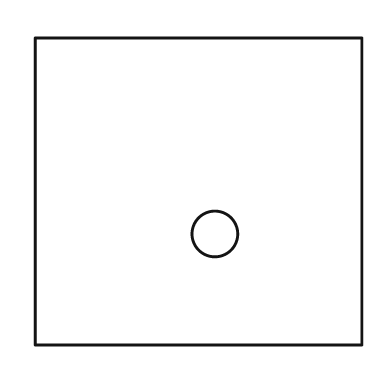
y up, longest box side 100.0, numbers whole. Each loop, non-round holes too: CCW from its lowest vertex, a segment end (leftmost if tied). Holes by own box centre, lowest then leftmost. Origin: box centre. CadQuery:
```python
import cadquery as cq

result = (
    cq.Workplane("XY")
    .moveTo(-50.0, -47.0)
    .lineTo(50.0, -47.0)
    .lineTo(50.0, 47.0)
    .lineTo(-50.0, 47.0)
    .close()
    .moveTo(5.0, -13.0)
    .circle(7.0)
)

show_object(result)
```